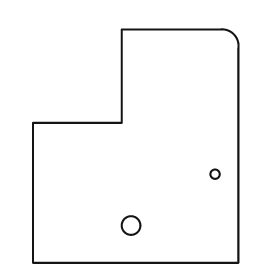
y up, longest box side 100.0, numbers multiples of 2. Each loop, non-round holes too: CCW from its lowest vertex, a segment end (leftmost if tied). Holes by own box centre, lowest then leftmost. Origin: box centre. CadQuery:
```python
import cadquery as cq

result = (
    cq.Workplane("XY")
    .moveTo(-44.0, -50.0)
    .lineTo(44.0, -50.0)
    .lineTo(44.0, 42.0)
    .threePointArc((42.0, 48.0), (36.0, 50.0))
    .lineTo(-6.0, 50.0)
    .lineTo(-6.0, 10.0)
    .lineTo(-44.0, 10.0)
    .close()
    .moveTo(-2.0, -34.0)
    .circle(4.0)
    .moveTo(34.0, -12.0)
    .circle(2.0)
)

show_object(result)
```